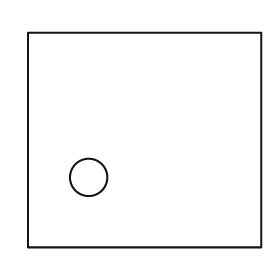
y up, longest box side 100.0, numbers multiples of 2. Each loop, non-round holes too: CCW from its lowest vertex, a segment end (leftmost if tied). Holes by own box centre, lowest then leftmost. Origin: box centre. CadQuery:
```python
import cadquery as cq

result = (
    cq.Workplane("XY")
    .moveTo(-50.0, -46.0)
    .lineTo(50.0, -46.0)
    .lineTo(50.0, 46.0)
    .lineTo(-50.0, 46.0)
    .close()
    .moveTo(-24.0, -16.0)
    .circle(8.0)
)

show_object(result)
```